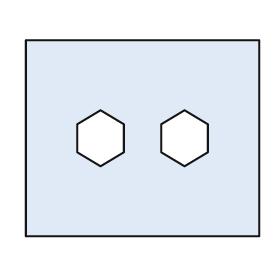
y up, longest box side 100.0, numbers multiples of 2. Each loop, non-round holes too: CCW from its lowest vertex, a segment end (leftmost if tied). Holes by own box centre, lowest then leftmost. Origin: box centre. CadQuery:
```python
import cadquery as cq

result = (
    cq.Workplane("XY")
    .moveTo(-50.0, -42.0)
    .lineTo(50.0, -42.0)
    .lineTo(50.0, 42.0)
    .lineTo(-50.0, 42.0)
    .close()
    .moveTo(-18.0, -12.0)
    .lineTo(-8.0, -6.0)
    .lineTo(-8.0, 6.0)
    .lineTo(-18.0, 12.0)
    .lineTo(-28.0, 6.0)
    .lineTo(-28.0, -6.0)
    .close()
    .moveTo(18.0, -12.0)
    .lineTo(28.0, -6.0)
    .lineTo(28.0, 6.0)
    .lineTo(18.0, 12.0)
    .lineTo(8.0, 6.0)
    .lineTo(8.0, -6.0)
    .close()
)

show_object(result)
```